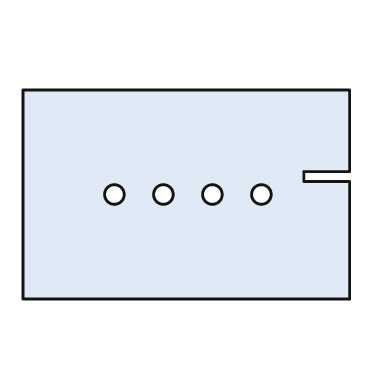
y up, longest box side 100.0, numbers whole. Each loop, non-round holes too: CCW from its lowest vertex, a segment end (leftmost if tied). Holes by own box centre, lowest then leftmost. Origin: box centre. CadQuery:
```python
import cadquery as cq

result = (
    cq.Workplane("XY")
    .moveTo(-50.0, -32.0)
    .lineTo(50.0, -32.0)
    .lineTo(50.0, 4.0)
    .lineTo(36.0, 4.0)
    .lineTo(36.0, 7.0)
    .lineTo(50.0, 7.0)
    .lineTo(50.0, 32.0)
    .lineTo(-50.0, 32.0)
    .close()
    .moveTo(-22.0, 0.0)
    .circle(3.0)
    .moveTo(-7.0, 0.0)
    .circle(3.0)
    .moveTo(8.0, 0.0)
    .circle(3.0)
    .moveTo(23.0, 0.0)
    .circle(3.0)
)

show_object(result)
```